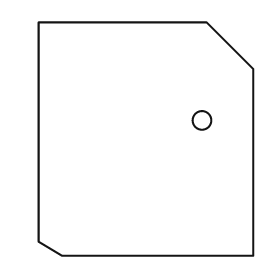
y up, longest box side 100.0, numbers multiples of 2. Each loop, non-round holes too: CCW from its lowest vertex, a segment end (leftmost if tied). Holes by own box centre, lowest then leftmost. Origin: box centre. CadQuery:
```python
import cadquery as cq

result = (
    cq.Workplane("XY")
    .moveTo(-36.0, -50.0)
    .lineTo(46.0, -50.0)
    .lineTo(46.0, 30.0)
    .lineTo(26.0, 50.0)
    .lineTo(-46.0, 50.0)
    .lineTo(-46.0, -44.0)
    .close()
    .moveTo(24.0, 8.0)
    .circle(4.0)
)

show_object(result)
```